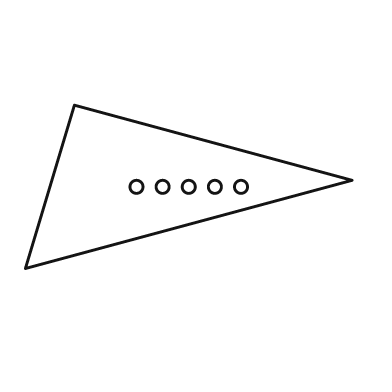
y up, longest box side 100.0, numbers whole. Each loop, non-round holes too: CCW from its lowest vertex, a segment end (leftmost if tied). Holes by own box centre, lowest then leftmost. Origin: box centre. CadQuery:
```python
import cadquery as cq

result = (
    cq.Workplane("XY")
    .moveTo(-50.0, -25.0)
    .lineTo(50.0, 2.0)
    .lineTo(-35.0, 25.0)
    .close()
    .moveTo(-16.0, 0.0)
    .circle(2.0)
    .moveTo(-8.0, 0.0)
    .circle(2.0)
    .moveTo(0.0, 0.0)
    .circle(2.0)
    .moveTo(8.0, 0.0)
    .circle(2.0)
    .moveTo(16.0, 0.0)
    .circle(2.0)
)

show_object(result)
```